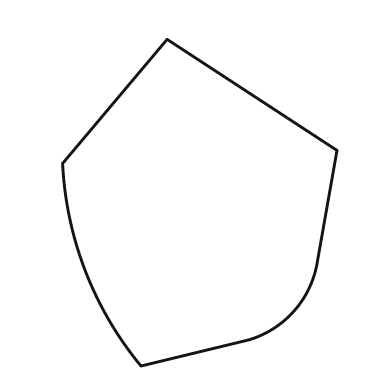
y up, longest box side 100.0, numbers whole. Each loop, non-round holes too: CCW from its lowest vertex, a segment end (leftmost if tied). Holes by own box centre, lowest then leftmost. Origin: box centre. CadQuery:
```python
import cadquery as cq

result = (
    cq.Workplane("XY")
    .moveTo(-18.0, -50.0)
    .lineTo(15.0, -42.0)
    .threePointArc((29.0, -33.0), (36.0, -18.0))
    .lineTo(42.0, 16.0)
    .lineTo(-10.0, 50.0)
    .lineTo(-42.0, 12.0)
    .threePointArc((-35.0, -21.0), (-18.0, -50.0))
    .close()
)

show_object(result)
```